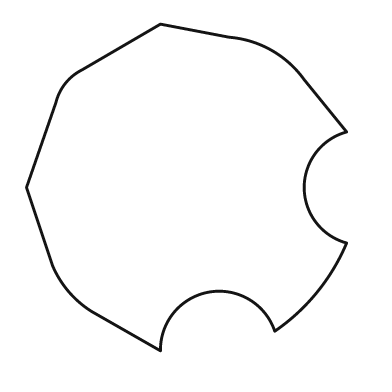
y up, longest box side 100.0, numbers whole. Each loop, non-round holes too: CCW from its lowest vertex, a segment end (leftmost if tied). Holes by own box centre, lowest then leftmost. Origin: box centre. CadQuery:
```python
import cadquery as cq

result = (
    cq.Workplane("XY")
    .moveTo(-8.0, -50.0)
    .threePointArc((7.0, -32.0), (27.0, -44.0))
    .threePointArc((40.0, -32.0), (49.0, -17.0))
    .threePointArc((36.0, 0.0), (49.0, 17.0))
    .lineTo(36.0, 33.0)
    .threePointArc((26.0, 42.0), (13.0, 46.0))
    .lineTo(-8.0, 50.0)
    .lineTo(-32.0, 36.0)
    .threePointArc((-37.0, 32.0), (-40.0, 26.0))
    .lineTo(-49.0, 0.0)
    .lineTo(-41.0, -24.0)
    .threePointArc((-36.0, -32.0), (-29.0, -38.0))
    .close()
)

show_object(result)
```